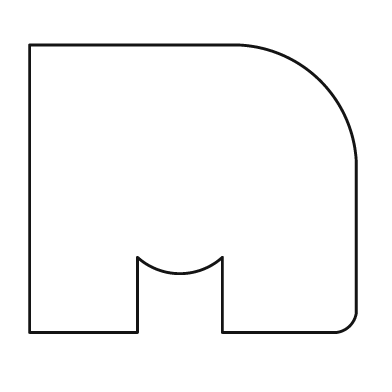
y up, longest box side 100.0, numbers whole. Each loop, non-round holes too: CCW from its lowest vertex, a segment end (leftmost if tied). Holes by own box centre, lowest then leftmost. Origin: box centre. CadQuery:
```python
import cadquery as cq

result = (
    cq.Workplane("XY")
    .moveTo(-50.0, -44.0)
    .lineTo(-17.0, -44.0)
    .lineTo(-17.0, -21.0)
    .threePointArc((-4.0, -26.0), (9.0, -21.0))
    .lineTo(9.0, -44.0)
    .lineTo(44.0, -44.0)
    .threePointArc((48.0, -42.0), (50.0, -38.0))
    .lineTo(50.0, 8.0)
    .threePointArc((39.0, 33.0), (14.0, 44.0))
    .lineTo(-50.0, 44.0)
    .close()
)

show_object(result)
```